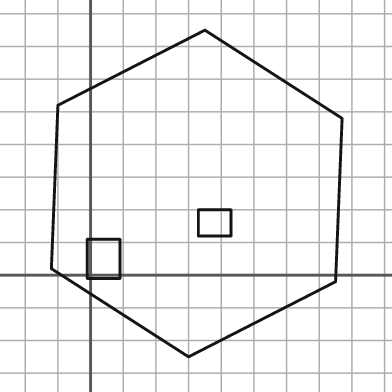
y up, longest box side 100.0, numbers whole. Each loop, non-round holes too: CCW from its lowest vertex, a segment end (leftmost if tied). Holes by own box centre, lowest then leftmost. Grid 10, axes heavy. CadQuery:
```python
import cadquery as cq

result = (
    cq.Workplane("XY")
    .moveTo(30.0, -25.0)
    .lineTo(75.0, -2.0)
    .lineTo(77.0, 48.0)
    .lineTo(35.0, 75.0)
    .lineTo(-10.0, 52.0)
    .lineTo(-12.0, 2.0)
    .close()
    .moveTo(-1.0, -1.0)
    .lineTo(9.0, -1.0)
    .lineTo(9.0, 11.0)
    .lineTo(-1.0, 11.0)
    .close()
    .moveTo(33.0, 12.0)
    .lineTo(43.0, 12.0)
    .lineTo(43.0, 20.0)
    .lineTo(33.0, 20.0)
    .close()
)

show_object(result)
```